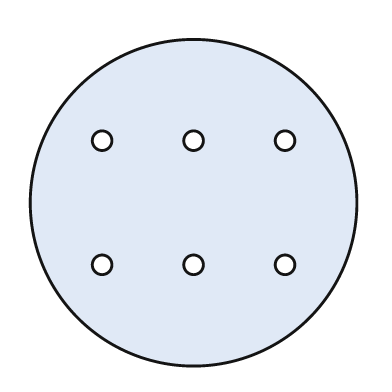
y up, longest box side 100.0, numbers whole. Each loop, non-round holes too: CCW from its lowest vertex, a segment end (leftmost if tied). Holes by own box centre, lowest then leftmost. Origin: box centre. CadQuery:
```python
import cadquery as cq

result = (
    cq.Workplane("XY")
    .moveTo(0.0, 0.0)
    .circle(50.0)
    .moveTo(-28.0, -19.0)
    .circle(3.0)
    .moveTo(0.0, -19.0)
    .circle(3.0)
    .moveTo(28.0, -19.0)
    .circle(3.0)
    .moveTo(-28.0, 19.0)
    .circle(3.0)
    .moveTo(0.0, 19.0)
    .circle(3.0)
    .moveTo(28.0, 19.0)
    .circle(3.0)
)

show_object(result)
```